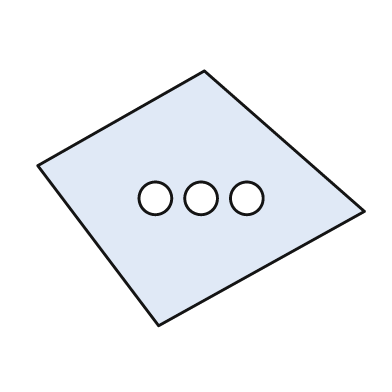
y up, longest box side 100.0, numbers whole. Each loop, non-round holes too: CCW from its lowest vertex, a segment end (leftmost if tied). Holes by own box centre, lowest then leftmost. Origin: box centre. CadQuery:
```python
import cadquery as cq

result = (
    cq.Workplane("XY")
    .moveTo(-13.0, -39.0)
    .lineTo(50.0, -4.0)
    .lineTo(1.0, 39.0)
    .lineTo(-50.0, 10.0)
    .close()
    .moveTo(-14.0, 0.0)
    .circle(5.0)
    .moveTo(0.0, 0.0)
    .circle(5.0)
    .moveTo(14.0, 0.0)
    .circle(5.0)
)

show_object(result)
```